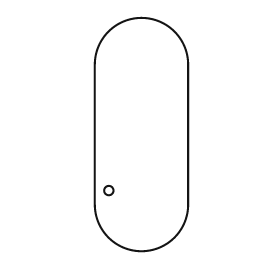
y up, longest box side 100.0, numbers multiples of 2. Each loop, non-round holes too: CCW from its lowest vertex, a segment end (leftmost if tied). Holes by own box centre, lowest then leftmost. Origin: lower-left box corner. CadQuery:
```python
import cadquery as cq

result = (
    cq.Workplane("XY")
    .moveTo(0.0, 20.0)
    .threePointArc((20.0, 0.0), (40.0, 20.0))
    .lineTo(40.0, 80.0)
    .threePointArc((20.0, 100.0), (0.0, 80.0))
    .close()
    .moveTo(6.0, 26.0)
    .circle(2.0)
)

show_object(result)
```